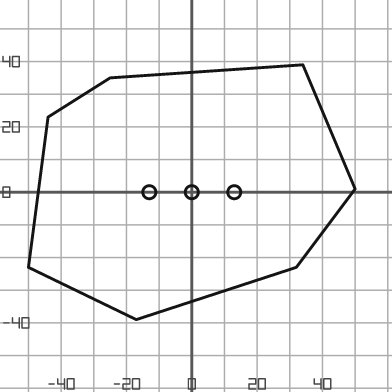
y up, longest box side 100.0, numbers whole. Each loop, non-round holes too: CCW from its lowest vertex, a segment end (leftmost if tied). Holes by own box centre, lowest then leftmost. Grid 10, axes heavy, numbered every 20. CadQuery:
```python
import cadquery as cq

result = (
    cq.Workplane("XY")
    .moveTo(-17.0, -39.0)
    .lineTo(32.0, -23.0)
    .lineTo(50.0, 1.0)
    .lineTo(34.0, 39.0)
    .lineTo(-25.0, 35.0)
    .lineTo(-44.0, 23.0)
    .lineTo(-50.0, -23.0)
    .close()
    .moveTo(-13.0, 0.0)
    .circle(2.0)
    .moveTo(0.0, 0.0)
    .circle(2.0)
    .moveTo(13.0, 0.0)
    .circle(2.0)
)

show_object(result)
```